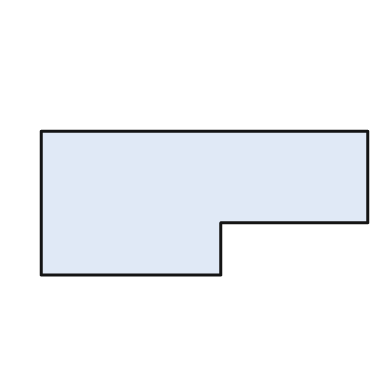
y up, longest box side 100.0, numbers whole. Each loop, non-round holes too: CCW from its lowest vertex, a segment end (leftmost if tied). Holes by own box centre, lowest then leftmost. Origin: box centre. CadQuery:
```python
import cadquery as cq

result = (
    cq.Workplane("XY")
    .moveTo(-50.0, -22.0)
    .lineTo(5.0, -22.0)
    .lineTo(5.0, -6.0)
    .lineTo(50.0, -6.0)
    .lineTo(50.0, 22.0)
    .lineTo(-50.0, 22.0)
    .close()
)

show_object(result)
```